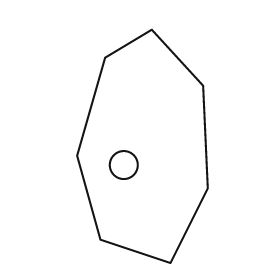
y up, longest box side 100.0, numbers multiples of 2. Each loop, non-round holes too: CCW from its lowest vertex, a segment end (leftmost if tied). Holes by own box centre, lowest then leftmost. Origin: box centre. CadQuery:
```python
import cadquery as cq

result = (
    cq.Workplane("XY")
    .moveTo(12.0, -50.0)
    .lineTo(28.0, -18.0)
    .lineTo(26.0, 26.0)
    .lineTo(4.0, 50.0)
    .lineTo(-16.0, 38.0)
    .lineTo(-28.0, -4.0)
    .lineTo(-18.0, -40.0)
    .close()
    .moveTo(-8.0, -8.0)
    .circle(6.0)
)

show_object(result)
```